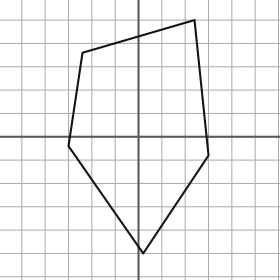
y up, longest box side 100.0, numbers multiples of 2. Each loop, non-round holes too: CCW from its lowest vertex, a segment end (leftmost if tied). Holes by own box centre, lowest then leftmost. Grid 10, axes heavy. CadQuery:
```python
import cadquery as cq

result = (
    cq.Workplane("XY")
    .moveTo(2.0, -50.0)
    .lineTo(30.0, -8.0)
    .lineTo(24.0, 50.0)
    .lineTo(-24.0, 36.0)
    .lineTo(-30.0, -4.0)
    .close()
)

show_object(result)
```